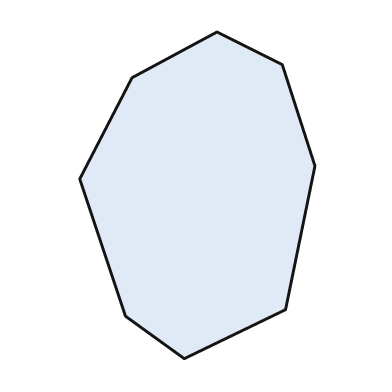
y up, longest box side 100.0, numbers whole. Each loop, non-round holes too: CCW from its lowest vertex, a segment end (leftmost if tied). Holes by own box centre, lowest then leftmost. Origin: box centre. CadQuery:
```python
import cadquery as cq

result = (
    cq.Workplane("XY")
    .moveTo(-4.0, -50.0)
    .lineTo(27.0, -35.0)
    .lineTo(36.0, 9.0)
    .lineTo(26.0, 40.0)
    .lineTo(6.0, 50.0)
    .lineTo(-20.0, 36.0)
    .lineTo(-36.0, 5.0)
    .lineTo(-22.0, -37.0)
    .close()
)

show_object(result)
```